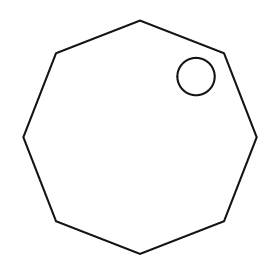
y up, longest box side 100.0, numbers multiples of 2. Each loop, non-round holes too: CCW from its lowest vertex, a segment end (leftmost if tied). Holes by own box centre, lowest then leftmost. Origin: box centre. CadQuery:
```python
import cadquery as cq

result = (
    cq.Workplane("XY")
    .moveTo(0.0, -50.0)
    .lineTo(36.0, -36.0)
    .lineTo(50.0, 0.0)
    .lineTo(36.0, 36.0)
    .lineTo(0.0, 50.0)
    .lineTo(-36.0, 36.0)
    .lineTo(-50.0, 0.0)
    .lineTo(-36.0, -36.0)
    .close()
    .moveTo(24.0, 26.0)
    .circle(8.0)
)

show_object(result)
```